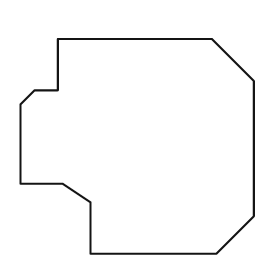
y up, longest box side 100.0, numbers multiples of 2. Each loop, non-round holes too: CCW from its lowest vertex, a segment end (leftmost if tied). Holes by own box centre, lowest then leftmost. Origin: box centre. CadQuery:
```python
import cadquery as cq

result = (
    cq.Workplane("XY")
    .moveTo(-20.0, -46.0)
    .lineTo(34.0, -46.0)
    .lineTo(50.0, -30.0)
    .lineTo(50.0, 28.0)
    .lineTo(32.0, 46.0)
    .lineTo(-34.0, 46.0)
    .lineTo(-34.0, 24.0)
    .lineTo(-44.0, 24.0)
    .lineTo(-50.0, 18.0)
    .lineTo(-50.0, -16.0)
    .lineTo(-32.0, -16.0)
    .lineTo(-20.0, -24.0)
    .close()
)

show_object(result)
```